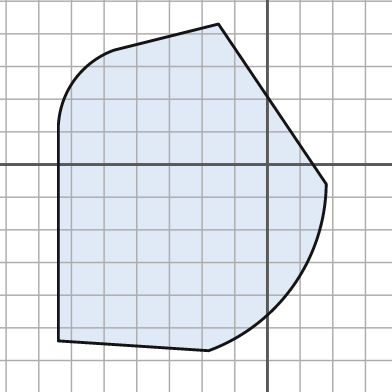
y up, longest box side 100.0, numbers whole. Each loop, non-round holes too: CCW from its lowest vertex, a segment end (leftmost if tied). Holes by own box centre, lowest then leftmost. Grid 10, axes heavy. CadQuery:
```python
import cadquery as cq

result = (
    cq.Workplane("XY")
    .moveTo(-18.0, -57.0)
    .threePointArc((8.0, -37.0), (18.0, -6.0))
    .lineTo(-15.0, 43.0)
    .lineTo(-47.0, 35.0)
    .threePointArc((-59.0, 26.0), (-64.0, 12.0))
    .lineTo(-64.0, -54.0)
    .close()
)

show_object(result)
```